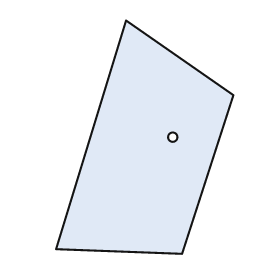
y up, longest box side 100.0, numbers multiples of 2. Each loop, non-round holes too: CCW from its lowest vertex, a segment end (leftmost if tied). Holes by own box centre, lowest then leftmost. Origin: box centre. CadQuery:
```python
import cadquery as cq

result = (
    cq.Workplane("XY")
    .moveTo(16.0, -50.0)
    .lineTo(38.0, 18.0)
    .lineTo(-8.0, 50.0)
    .lineTo(-38.0, -48.0)
    .close()
    .moveTo(12.0, 0.0)
    .circle(2.0)
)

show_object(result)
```